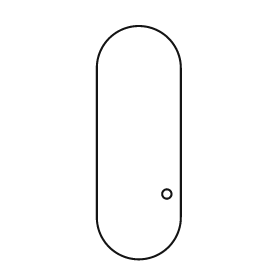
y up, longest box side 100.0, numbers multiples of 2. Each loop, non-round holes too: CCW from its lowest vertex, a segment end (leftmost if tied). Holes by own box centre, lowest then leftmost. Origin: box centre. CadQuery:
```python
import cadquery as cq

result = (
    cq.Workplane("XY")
    .moveTo(-18.0, -32.0)
    .threePointArc((0.0, -50.0), (18.0, -32.0))
    .lineTo(18.0, 32.0)
    .threePointArc((0.0, 50.0), (-18.0, 32.0))
    .close()
    .moveTo(12.0, -22.0)
    .circle(2.0)
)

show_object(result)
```